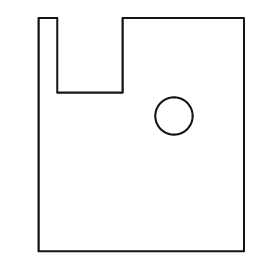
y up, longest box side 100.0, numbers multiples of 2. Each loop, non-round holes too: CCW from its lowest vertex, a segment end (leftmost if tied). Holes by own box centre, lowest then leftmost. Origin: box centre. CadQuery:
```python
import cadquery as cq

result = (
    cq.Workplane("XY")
    .moveTo(-44.0, -50.0)
    .lineTo(44.0, -50.0)
    .lineTo(44.0, 50.0)
    .lineTo(-8.0, 50.0)
    .lineTo(-8.0, 18.0)
    .lineTo(-36.0, 18.0)
    .lineTo(-36.0, 50.0)
    .lineTo(-44.0, 50.0)
    .close()
    .moveTo(14.0, 8.0)
    .circle(8.0)
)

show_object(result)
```